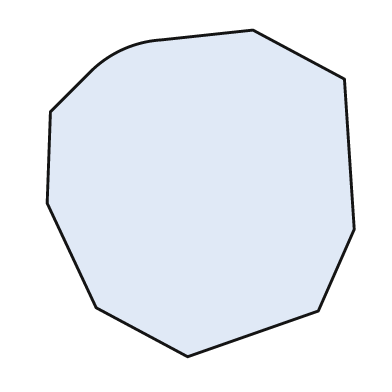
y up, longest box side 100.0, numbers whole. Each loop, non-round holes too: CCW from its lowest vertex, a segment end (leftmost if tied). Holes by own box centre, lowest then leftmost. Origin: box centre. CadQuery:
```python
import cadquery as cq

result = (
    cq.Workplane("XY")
    .moveTo(-4.0, -50.0)
    .lineTo(36.0, -36.0)
    .lineTo(47.0, -11.0)
    .lineTo(44.0, 35.0)
    .lineTo(16.0, 50.0)
    .lineTo(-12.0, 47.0)
    .threePointArc((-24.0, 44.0), (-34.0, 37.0))
    .lineTo(-46.0, 25.0)
    .lineTo(-47.0, -3.0)
    .lineTo(-32.0, -35.0)
    .close()
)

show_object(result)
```